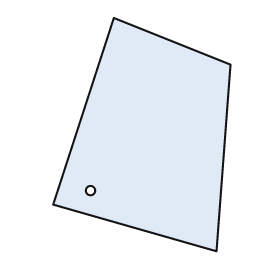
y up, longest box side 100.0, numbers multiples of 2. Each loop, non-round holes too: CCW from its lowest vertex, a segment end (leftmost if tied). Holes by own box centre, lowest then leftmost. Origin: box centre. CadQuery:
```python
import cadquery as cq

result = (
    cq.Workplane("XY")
    .moveTo(32.0, -50.0)
    .lineTo(38.0, 30.0)
    .lineTo(-12.0, 50.0)
    .lineTo(-38.0, -30.0)
    .close()
    .moveTo(-22.0, -24.0)
    .circle(2.0)
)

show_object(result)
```